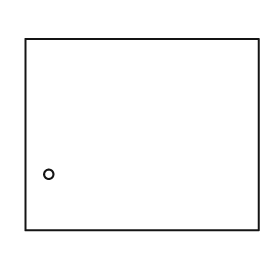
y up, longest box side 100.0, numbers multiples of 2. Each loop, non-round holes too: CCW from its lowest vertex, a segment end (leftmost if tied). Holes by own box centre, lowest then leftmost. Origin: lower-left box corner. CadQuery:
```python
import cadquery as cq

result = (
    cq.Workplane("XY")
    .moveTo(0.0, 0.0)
    .lineTo(100.0, 0.0)
    .lineTo(100.0, 82.0)
    .lineTo(0.0, 82.0)
    .close()
    .moveTo(10.0, 24.0)
    .circle(2.0)
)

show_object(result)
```